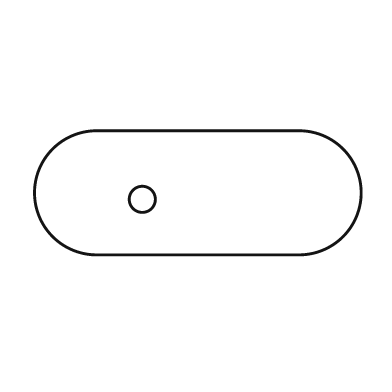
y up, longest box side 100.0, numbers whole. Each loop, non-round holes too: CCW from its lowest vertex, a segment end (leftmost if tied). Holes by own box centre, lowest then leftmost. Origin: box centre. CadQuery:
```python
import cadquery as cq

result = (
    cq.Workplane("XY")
    .moveTo(-31.0, -19.0)
    .lineTo(31.0, -19.0)
    .threePointArc((50.0, 0.0), (31.0, 19.0))
    .lineTo(-31.0, 19.0)
    .threePointArc((-50.0, 0.0), (-31.0, -19.0))
    .close()
    .moveTo(-17.0, -2.0)
    .circle(4.0)
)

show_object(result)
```